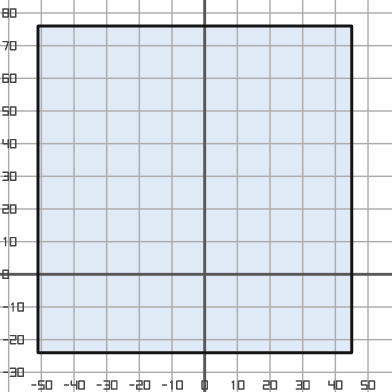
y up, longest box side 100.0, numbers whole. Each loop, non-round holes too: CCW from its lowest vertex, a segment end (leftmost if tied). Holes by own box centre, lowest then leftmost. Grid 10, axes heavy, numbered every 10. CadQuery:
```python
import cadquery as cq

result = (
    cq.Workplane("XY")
    .moveTo(-51.0, -24.0)
    .lineTo(45.0, -24.0)
    .lineTo(45.0, 76.0)
    .lineTo(-51.0, 76.0)
    .close()
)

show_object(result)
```